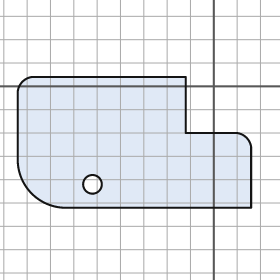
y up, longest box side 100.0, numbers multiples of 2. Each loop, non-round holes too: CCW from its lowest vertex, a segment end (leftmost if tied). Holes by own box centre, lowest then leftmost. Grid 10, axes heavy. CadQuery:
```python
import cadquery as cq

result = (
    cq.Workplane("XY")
    .moveTo(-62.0, -52.0)
    .lineTo(16.0, -52.0)
    .lineTo(16.0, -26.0)
    .threePointArc((14.0, -22.0), (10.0, -20.0))
    .lineTo(-12.0, -20.0)
    .lineTo(-12.0, 4.0)
    .lineTo(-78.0, 4.0)
    .threePointArc((-82.0, 2.0), (-84.0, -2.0))
    .lineTo(-84.0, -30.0)
    .threePointArc((-78.0, -46.0), (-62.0, -52.0))
    .close()
    .moveTo(-52.0, -42.0)
    .circle(4.0)
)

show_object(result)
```